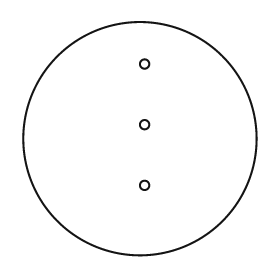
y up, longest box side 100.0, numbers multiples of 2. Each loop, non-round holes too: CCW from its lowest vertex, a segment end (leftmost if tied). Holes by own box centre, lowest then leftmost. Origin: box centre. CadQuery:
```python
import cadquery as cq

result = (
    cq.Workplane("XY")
    .moveTo(0.0, 0.0)
    .circle(50.0)
    .moveTo(2.0, -20.0)
    .circle(2.0)
    .moveTo(2.0, 6.0)
    .circle(2.0)
    .moveTo(2.0, 32.0)
    .circle(2.0)
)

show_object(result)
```